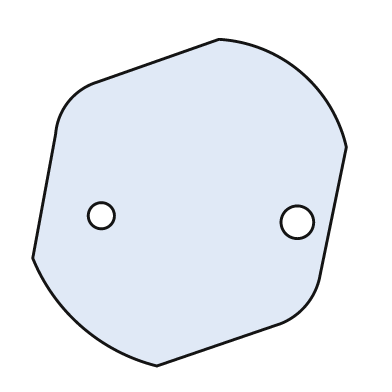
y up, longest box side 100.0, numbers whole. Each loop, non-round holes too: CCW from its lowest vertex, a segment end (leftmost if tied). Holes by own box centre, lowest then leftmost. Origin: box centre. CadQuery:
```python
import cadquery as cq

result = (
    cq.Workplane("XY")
    .moveTo(-10.0, -50.0)
    .lineTo(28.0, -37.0)
    .threePointArc((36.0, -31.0), (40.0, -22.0))
    .lineTo(48.0, 17.0)
    .threePointArc((34.0, 40.0), (9.0, 50.0))
    .lineTo(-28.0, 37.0)
    .threePointArc((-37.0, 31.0), (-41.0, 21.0))
    .lineTo(-48.0, -17.0)
    .threePointArc((-33.0, -38.0), (-10.0, -50.0))
    .close()
    .moveTo(33.0, -6.0)
    .circle(5.0)
    .moveTo(-27.0, -4.0)
    .circle(4.0)
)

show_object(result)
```